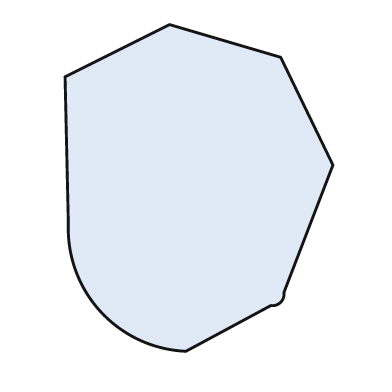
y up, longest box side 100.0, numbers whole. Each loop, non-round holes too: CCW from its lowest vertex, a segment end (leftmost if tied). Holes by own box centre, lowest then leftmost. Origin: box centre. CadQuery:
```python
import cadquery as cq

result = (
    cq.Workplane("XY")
    .moveTo(-4.0, -50.0)
    .lineTo(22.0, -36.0)
    .threePointArc((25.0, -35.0), (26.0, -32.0))
    .lineTo(41.0, 7.0)
    .lineTo(25.0, 40.0)
    .lineTo(-9.0, 50.0)
    .lineTo(-41.0, 34.0)
    .lineTo(-40.0, -11.0)
    .threePointArc((-30.0, -38.0), (-4.0, -50.0))
    .close()
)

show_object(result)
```